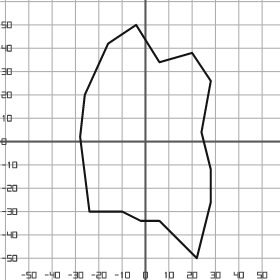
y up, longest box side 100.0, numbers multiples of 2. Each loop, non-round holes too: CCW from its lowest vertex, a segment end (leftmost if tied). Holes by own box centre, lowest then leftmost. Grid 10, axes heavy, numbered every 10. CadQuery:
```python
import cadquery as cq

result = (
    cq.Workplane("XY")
    .moveTo(22.0, -50.0)
    .lineTo(28.0, -26.0)
    .lineTo(28.0, -12.0)
    .lineTo(24.0, 4.0)
    .lineTo(28.0, 26.0)
    .lineTo(20.0, 38.0)
    .lineTo(6.0, 34.0)
    .lineTo(-4.0, 50.0)
    .lineTo(-16.0, 42.0)
    .lineTo(-26.0, 20.0)
    .lineTo(-28.0, 2.0)
    .lineTo(-24.0, -30.0)
    .lineTo(-10.0, -30.0)
    .lineTo(-2.0, -34.0)
    .lineTo(6.0, -34.0)
    .close()
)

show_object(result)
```